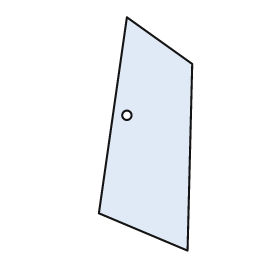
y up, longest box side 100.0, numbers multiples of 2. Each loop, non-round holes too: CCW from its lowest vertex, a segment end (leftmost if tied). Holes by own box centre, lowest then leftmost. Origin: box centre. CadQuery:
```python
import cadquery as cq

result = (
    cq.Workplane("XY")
    .moveTo(18.0, -50.0)
    .lineTo(20.0, 30.0)
    .lineTo(-8.0, 50.0)
    .lineTo(-20.0, -34.0)
    .close()
    .moveTo(-8.0, 8.0)
    .circle(2.0)
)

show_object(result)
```